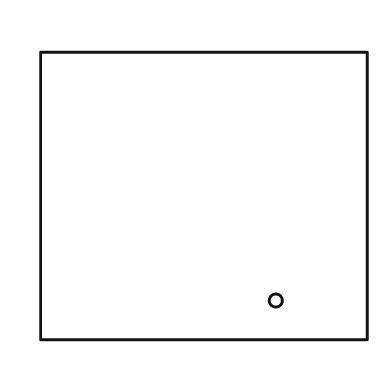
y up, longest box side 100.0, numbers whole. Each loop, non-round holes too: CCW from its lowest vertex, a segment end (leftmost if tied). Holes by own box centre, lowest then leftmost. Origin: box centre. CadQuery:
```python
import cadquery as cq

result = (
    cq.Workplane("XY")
    .moveTo(-50.0, -44.0)
    .lineTo(50.0, -44.0)
    .lineTo(50.0, 44.0)
    .lineTo(-50.0, 44.0)
    .close()
    .moveTo(22.0, -32.0)
    .circle(2.0)
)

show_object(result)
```